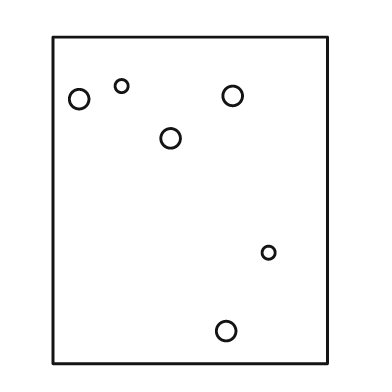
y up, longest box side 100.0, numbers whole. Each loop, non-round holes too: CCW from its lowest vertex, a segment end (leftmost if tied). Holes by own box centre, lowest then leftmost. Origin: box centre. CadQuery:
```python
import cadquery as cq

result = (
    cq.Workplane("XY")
    .moveTo(-42.0, -50.0)
    .lineTo(42.0, -50.0)
    .lineTo(42.0, 50.0)
    .lineTo(-42.0, 50.0)
    .close()
    .moveTo(11.0, -40.0)
    .circle(3.0)
    .moveTo(24.0, -16.0)
    .circle(2.0)
    .moveTo(-6.0, 19.0)
    .circle(3.0)
    .moveTo(-34.0, 31.0)
    .circle(3.0)
    .moveTo(13.0, 32.0)
    .circle(3.0)
    .moveTo(-21.0, 35.0)
    .circle(2.0)
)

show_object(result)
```